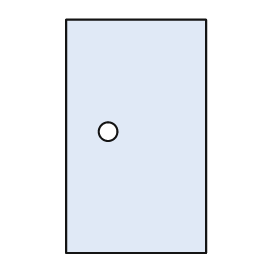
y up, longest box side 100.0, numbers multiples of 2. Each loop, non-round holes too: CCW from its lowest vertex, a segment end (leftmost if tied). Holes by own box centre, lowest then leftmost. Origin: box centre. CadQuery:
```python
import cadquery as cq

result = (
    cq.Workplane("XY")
    .moveTo(-30.0, -50.0)
    .lineTo(30.0, -50.0)
    .lineTo(30.0, 50.0)
    .lineTo(-30.0, 50.0)
    .close()
    .moveTo(-12.0, 2.0)
    .circle(4.0)
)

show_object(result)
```